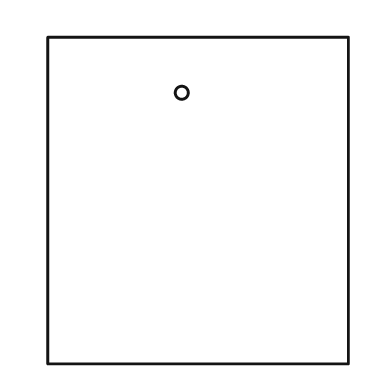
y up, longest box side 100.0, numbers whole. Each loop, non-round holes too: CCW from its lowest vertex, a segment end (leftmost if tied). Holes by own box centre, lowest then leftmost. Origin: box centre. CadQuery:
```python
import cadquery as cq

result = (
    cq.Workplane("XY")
    .moveTo(-46.0, -50.0)
    .lineTo(46.0, -50.0)
    .lineTo(46.0, 50.0)
    .lineTo(-46.0, 50.0)
    .close()
    .moveTo(-5.0, 33.0)
    .circle(2.0)
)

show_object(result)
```